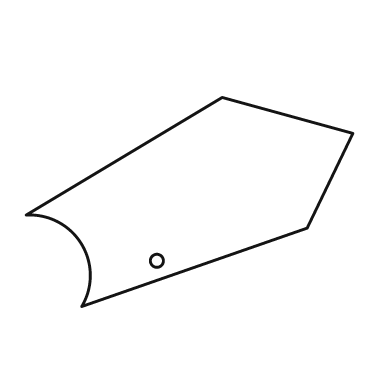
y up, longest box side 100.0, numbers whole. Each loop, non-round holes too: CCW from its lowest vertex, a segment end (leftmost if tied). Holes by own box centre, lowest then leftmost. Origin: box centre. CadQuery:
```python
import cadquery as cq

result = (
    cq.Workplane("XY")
    .moveTo(-33.0, -32.0)
    .lineTo(36.0, -8.0)
    .lineTo(50.0, 21.0)
    .lineTo(10.0, 32.0)
    .lineTo(-50.0, -4.0)
    .threePointArc((-33.0, -13.0), (-33.0, -32.0))
    .close()
    .moveTo(-10.0, -18.0)
    .circle(2.0)
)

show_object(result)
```